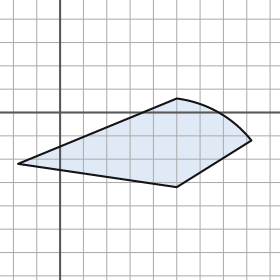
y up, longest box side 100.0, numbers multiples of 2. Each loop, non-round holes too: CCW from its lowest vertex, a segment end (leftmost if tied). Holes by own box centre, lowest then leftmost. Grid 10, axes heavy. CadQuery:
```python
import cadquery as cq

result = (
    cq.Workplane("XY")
    .moveTo(50.0, -32.0)
    .lineTo(82.0, -12.0)
    .threePointArc((68.0, 0.0), (50.0, 6.0))
    .lineTo(-18.0, -22.0)
    .close()
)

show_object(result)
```